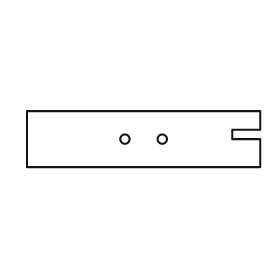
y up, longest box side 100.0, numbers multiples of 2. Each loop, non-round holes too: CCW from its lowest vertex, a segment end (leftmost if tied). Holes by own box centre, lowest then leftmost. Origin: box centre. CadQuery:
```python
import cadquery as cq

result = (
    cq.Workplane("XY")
    .moveTo(-50.0, -12.0)
    .lineTo(50.0, -12.0)
    .lineTo(50.0, 0.0)
    .lineTo(38.0, 0.0)
    .lineTo(38.0, 4.0)
    .lineTo(50.0, 4.0)
    .lineTo(50.0, 12.0)
    .lineTo(-50.0, 12.0)
    .close()
    .moveTo(-8.0, 0.0)
    .circle(2.0)
    .moveTo(8.0, 0.0)
    .circle(2.0)
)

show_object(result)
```